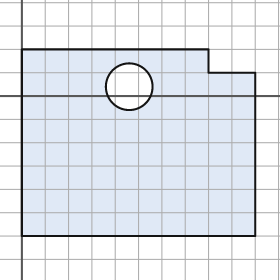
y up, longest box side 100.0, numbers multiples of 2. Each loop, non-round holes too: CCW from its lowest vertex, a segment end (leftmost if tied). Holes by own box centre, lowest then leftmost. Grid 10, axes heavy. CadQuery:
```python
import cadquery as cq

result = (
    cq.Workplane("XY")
    .moveTo(0.0, -60.0)
    .lineTo(100.0, -60.0)
    .lineTo(100.0, 10.0)
    .lineTo(80.0, 10.0)
    .lineTo(80.0, 20.0)
    .lineTo(0.0, 20.0)
    .close()
    .moveTo(46.0, 4.0)
    .circle(10.0)
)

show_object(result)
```